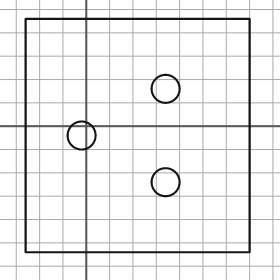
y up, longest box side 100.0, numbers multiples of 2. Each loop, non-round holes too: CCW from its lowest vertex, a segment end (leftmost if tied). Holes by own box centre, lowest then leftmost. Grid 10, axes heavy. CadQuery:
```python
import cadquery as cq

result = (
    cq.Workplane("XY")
    .moveTo(-26.0, -54.0)
    .lineTo(70.0, -54.0)
    .lineTo(70.0, 46.0)
    .lineTo(-26.0, 46.0)
    .close()
    .moveTo(34.0, -24.0)
    .circle(6.0)
    .moveTo(-2.0, -4.0)
    .circle(6.0)
    .moveTo(34.0, 16.0)
    .circle(6.0)
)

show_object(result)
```